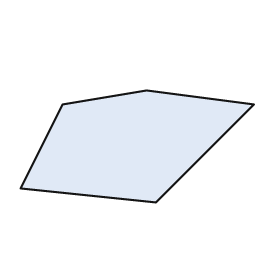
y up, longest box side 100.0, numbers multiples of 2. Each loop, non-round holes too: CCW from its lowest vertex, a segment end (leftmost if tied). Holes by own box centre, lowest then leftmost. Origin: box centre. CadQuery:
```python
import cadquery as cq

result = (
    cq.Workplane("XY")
    .moveTo(8.0, -24.0)
    .lineTo(50.0, 18.0)
    .lineTo(4.0, 24.0)
    .lineTo(-32.0, 18.0)
    .lineTo(-50.0, -18.0)
    .close()
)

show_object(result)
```